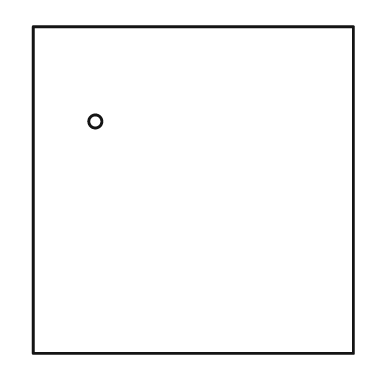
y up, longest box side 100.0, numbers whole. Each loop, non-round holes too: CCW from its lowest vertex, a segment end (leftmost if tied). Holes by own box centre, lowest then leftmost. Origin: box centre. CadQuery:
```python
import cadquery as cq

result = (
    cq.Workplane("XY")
    .moveTo(-49.0, -50.0)
    .lineTo(49.0, -50.0)
    .lineTo(49.0, 50.0)
    .lineTo(-49.0, 50.0)
    .close()
    .moveTo(-30.0, 21.0)
    .circle(2.0)
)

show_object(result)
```